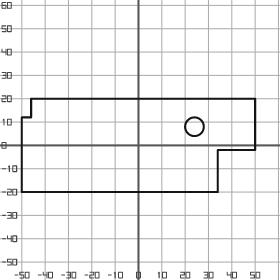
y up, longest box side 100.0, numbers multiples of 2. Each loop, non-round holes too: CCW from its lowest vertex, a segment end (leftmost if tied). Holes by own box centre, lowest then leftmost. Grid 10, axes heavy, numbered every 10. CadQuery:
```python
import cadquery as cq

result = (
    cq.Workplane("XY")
    .moveTo(-50.0, -20.0)
    .lineTo(34.0, -20.0)
    .lineTo(34.0, -2.0)
    .lineTo(50.0, -2.0)
    .lineTo(50.0, 20.0)
    .lineTo(-46.0, 20.0)
    .lineTo(-46.0, 12.0)
    .lineTo(-50.0, 12.0)
    .close()
    .moveTo(24.0, 8.0)
    .circle(4.0)
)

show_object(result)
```